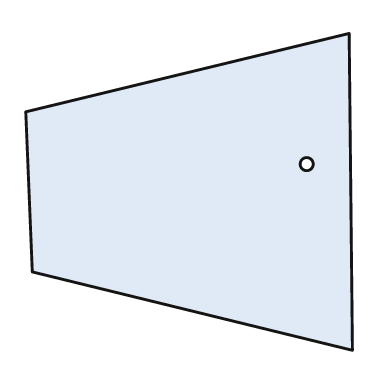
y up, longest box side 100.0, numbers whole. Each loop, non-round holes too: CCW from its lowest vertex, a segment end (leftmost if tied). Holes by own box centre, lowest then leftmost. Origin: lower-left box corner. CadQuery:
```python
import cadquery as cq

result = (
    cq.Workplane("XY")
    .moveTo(100.0, 0.0)
    .lineTo(99.0, 97.0)
    .lineTo(0.0, 73.0)
    .lineTo(2.0, 24.0)
    .close()
    .moveTo(86.0, 57.0)
    .circle(2.0)
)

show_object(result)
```